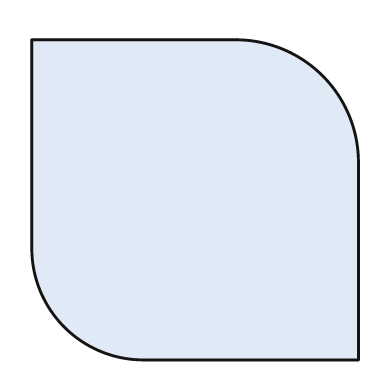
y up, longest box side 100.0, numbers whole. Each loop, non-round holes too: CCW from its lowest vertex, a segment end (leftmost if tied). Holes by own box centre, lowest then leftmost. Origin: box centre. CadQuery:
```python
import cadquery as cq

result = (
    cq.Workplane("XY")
    .moveTo(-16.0, -49.0)
    .lineTo(50.0, -49.0)
    .lineTo(50.0, 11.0)
    .threePointArc((39.0, 38.0), (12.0, 49.0))
    .lineTo(-50.0, 49.0)
    .lineTo(-50.0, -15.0)
    .threePointArc((-40.0, -39.0), (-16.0, -49.0))
    .close()
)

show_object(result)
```